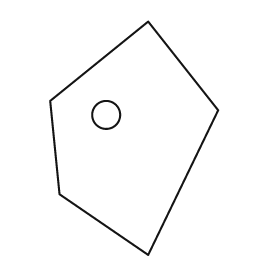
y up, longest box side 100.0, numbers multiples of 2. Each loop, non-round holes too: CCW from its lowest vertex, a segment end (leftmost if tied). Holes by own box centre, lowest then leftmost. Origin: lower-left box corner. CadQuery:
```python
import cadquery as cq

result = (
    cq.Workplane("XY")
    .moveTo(42.0, 0.0)
    .lineTo(72.0, 62.0)
    .lineTo(42.0, 100.0)
    .lineTo(0.0, 66.0)
    .lineTo(4.0, 26.0)
    .close()
    .moveTo(24.0, 60.0)
    .circle(6.0)
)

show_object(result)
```